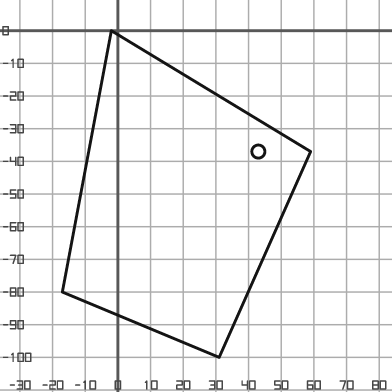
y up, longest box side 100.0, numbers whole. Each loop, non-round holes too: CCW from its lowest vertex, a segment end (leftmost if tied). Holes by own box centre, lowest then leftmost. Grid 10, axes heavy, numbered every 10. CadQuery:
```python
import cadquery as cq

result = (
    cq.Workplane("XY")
    .moveTo(31.0, -100.0)
    .lineTo(59.0, -37.0)
    .lineTo(-2.0, 0.0)
    .lineTo(-17.0, -80.0)
    .close()
    .moveTo(43.0, -37.0)
    .circle(2.0)
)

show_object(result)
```